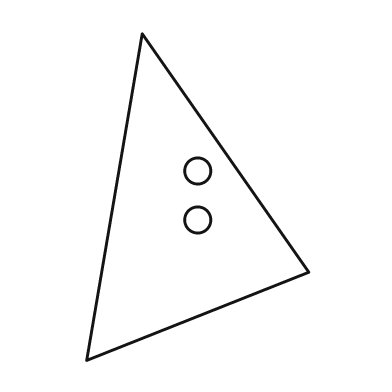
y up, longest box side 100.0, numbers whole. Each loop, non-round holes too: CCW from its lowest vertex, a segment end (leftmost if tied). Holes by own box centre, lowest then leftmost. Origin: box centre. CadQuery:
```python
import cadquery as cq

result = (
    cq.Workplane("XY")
    .moveTo(-34.0, -50.0)
    .lineTo(34.0, -23.0)
    .lineTo(-17.0, 50.0)
    .close()
    .moveTo(0.0, -7.0)
    .circle(4.0)
    .moveTo(0.0, 8.0)
    .circle(4.0)
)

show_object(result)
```